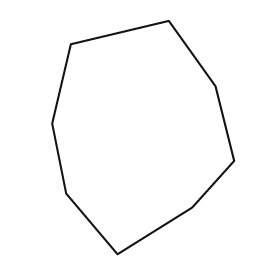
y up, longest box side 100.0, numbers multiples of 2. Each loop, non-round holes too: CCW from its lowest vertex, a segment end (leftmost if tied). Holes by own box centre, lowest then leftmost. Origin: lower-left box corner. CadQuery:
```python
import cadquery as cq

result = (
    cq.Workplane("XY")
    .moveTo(28.0, 0.0)
    .lineTo(60.0, 20.0)
    .lineTo(78.0, 40.0)
    .lineTo(70.0, 72.0)
    .lineTo(50.0, 100.0)
    .lineTo(8.0, 90.0)
    .lineTo(0.0, 56.0)
    .lineTo(6.0, 26.0)
    .close()
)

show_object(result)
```